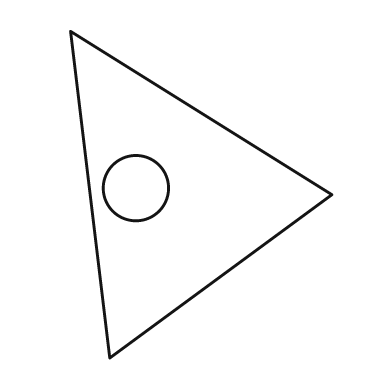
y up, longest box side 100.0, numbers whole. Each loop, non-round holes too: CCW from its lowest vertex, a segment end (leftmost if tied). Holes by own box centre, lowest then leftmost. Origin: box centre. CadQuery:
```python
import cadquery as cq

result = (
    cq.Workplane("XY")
    .moveTo(-28.0, -50.0)
    .lineTo(40.0, 0.0)
    .lineTo(-40.0, 50.0)
    .close()
    .moveTo(-20.0, 2.0)
    .circle(10.0)
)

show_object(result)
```